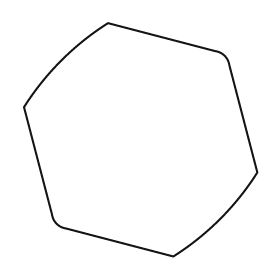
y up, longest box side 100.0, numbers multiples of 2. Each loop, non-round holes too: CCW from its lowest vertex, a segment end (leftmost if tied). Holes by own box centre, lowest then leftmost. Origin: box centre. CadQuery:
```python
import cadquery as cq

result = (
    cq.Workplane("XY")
    .moveTo(14.0, -50.0)
    .threePointArc((34.0, -34.0), (50.0, -14.0))
    .lineTo(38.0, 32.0)
    .threePointArc((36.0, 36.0), (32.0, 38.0))
    .lineTo(-14.0, 50.0)
    .threePointArc((-34.0, 34.0), (-50.0, 14.0))
    .lineTo(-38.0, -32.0)
    .threePointArc((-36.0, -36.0), (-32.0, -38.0))
    .close()
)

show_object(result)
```